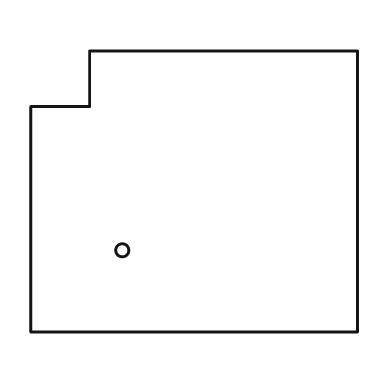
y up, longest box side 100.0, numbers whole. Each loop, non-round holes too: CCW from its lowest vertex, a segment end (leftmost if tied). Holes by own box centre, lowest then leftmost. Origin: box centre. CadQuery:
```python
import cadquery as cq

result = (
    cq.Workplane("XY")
    .moveTo(-50.0, -43.0)
    .lineTo(50.0, -43.0)
    .lineTo(50.0, 43.0)
    .lineTo(-32.0, 43.0)
    .lineTo(-32.0, 26.0)
    .lineTo(-50.0, 26.0)
    .close()
    .moveTo(-22.0, -18.0)
    .circle(2.0)
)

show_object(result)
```